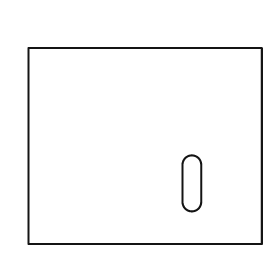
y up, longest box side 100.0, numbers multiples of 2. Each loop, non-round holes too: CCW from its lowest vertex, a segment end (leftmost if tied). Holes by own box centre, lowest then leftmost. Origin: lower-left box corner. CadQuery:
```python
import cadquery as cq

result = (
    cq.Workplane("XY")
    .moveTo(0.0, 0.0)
    .lineTo(100.0, 0.0)
    .lineTo(100.0, 84.0)
    .lineTo(0.0, 84.0)
    .close()
    .moveTo(66.0, 18.0)
    .threePointArc((70.0, 14.0), (74.0, 18.0))
    .lineTo(74.0, 34.0)
    .threePointArc((70.0, 38.0), (66.0, 34.0))
    .close()
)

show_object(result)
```